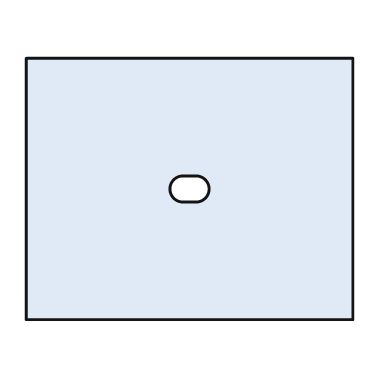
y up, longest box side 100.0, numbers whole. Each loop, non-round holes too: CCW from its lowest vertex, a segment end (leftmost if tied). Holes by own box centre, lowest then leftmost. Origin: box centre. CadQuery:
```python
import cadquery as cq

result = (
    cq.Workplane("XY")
    .moveTo(-50.0, -40.0)
    .lineTo(50.0, -40.0)
    .lineTo(50.0, 40.0)
    .lineTo(-50.0, 40.0)
    .close()
    .moveTo(-2.0, -4.0)
    .lineTo(2.0, -4.0)
    .threePointArc((6.0, 0.0), (2.0, 4.0))
    .lineTo(-2.0, 4.0)
    .threePointArc((-6.0, 0.0), (-2.0, -4.0))
    .close()
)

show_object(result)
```